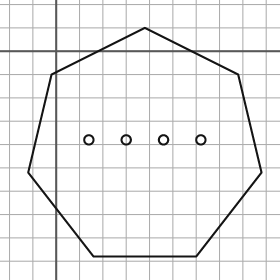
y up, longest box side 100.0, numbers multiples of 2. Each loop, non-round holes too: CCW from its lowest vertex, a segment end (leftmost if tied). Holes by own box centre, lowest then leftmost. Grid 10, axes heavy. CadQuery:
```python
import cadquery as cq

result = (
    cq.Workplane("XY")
    .moveTo(16.0, -88.0)
    .lineTo(60.0, -88.0)
    .lineTo(88.0, -52.0)
    .lineTo(78.0, -10.0)
    .lineTo(38.0, 10.0)
    .lineTo(-2.0, -10.0)
    .lineTo(-12.0, -52.0)
    .close()
    .moveTo(14.0, -38.0)
    .circle(2.0)
    .moveTo(30.0, -38.0)
    .circle(2.0)
    .moveTo(46.0, -38.0)
    .circle(2.0)
    .moveTo(62.0, -38.0)
    .circle(2.0)
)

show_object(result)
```